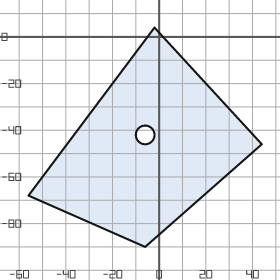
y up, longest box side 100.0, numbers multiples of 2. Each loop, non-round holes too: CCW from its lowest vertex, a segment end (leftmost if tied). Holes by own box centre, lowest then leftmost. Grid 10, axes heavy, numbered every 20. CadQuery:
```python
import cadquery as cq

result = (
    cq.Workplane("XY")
    .moveTo(-6.0, -90.0)
    .lineTo(44.0, -46.0)
    .lineTo(-2.0, 4.0)
    .lineTo(-56.0, -68.0)
    .close()
    .moveTo(-6.0, -42.0)
    .circle(4.0)
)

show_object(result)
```